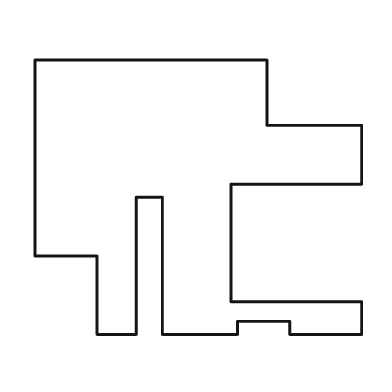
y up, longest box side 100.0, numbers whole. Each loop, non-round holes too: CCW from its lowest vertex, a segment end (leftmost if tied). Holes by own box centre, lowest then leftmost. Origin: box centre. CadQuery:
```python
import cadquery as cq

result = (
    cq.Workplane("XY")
    .moveTo(-31.0, -42.0)
    .lineTo(-19.0, -42.0)
    .lineTo(-19.0, 0.0)
    .lineTo(-11.0, 0.0)
    .lineTo(-11.0, -42.0)
    .lineTo(12.0, -42.0)
    .lineTo(12.0, -38.0)
    .lineTo(28.0, -38.0)
    .lineTo(28.0, -42.0)
    .lineTo(50.0, -42.0)
    .lineTo(50.0, -32.0)
    .lineTo(10.0, -32.0)
    .lineTo(10.0, 4.0)
    .lineTo(50.0, 4.0)
    .lineTo(50.0, 22.0)
    .lineTo(21.0, 22.0)
    .lineTo(21.0, 42.0)
    .lineTo(-50.0, 42.0)
    .lineTo(-50.0, -18.0)
    .lineTo(-31.0, -18.0)
    .close()
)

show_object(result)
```